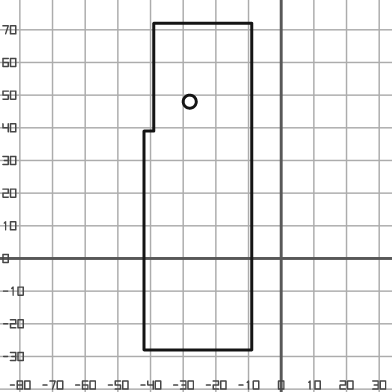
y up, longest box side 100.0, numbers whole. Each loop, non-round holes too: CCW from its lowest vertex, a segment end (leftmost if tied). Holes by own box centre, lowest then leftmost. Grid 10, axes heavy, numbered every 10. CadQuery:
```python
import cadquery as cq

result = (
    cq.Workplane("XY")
    .moveTo(-42.0, -28.0)
    .lineTo(-9.0, -28.0)
    .lineTo(-9.0, 72.0)
    .lineTo(-39.0, 72.0)
    .lineTo(-39.0, 39.0)
    .lineTo(-42.0, 39.0)
    .close()
    .moveTo(-28.0, 48.0)
    .circle(2.0)
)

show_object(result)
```